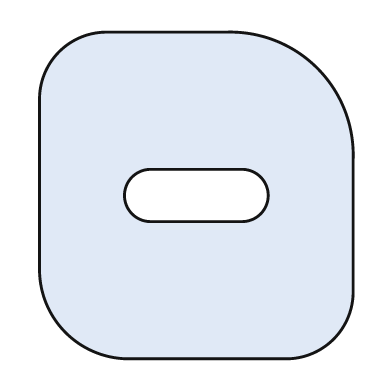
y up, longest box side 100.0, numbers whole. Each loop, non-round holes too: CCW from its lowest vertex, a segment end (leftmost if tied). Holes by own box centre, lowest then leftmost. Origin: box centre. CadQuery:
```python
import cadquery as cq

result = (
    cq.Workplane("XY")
    .moveTo(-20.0, -50.0)
    .lineTo(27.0, -50.0)
    .threePointArc((42.0, -44.0), (48.0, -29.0))
    .lineTo(48.0, 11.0)
    .threePointArc((37.0, 39.0), (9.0, 50.0))
    .lineTo(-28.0, 50.0)
    .threePointArc((-42.0, 44.0), (-48.0, 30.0))
    .lineTo(-48.0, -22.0)
    .threePointArc((-40.0, -42.0), (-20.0, -50.0))
    .close()
    .moveTo(-14.0, -8.0)
    .lineTo(14.0, -8.0)
    .threePointArc((22.0, 0.0), (14.0, 8.0))
    .lineTo(-14.0, 8.0)
    .threePointArc((-22.0, 0.0), (-14.0, -8.0))
    .close()
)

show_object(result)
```